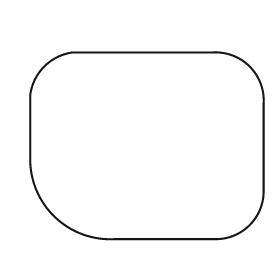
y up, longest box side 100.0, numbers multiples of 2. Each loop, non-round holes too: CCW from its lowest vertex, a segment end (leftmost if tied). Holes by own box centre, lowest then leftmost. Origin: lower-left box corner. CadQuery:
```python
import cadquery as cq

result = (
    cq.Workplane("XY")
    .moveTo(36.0, 0.0)
    .lineTo(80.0, 0.0)
    .threePointArc((94.0, 6.0), (100.0, 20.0))
    .lineTo(100.0, 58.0)
    .threePointArc((94.0, 74.0), (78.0, 80.0))
    .lineTo(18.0, 80.0)
    .threePointArc((6.0, 74.0), (0.0, 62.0))
    .lineTo(0.0, 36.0)
    .threePointArc((10.0, 10.0), (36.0, 0.0))
    .close()
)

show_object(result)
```